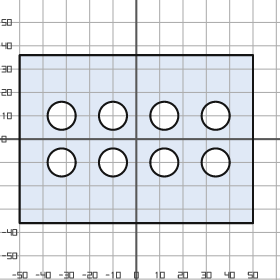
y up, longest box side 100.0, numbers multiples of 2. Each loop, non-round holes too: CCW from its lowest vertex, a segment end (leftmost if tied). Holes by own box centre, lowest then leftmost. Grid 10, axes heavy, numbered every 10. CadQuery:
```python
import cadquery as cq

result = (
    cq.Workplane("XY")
    .moveTo(-50.0, -36.0)
    .lineTo(50.0, -36.0)
    .lineTo(50.0, 36.0)
    .lineTo(-50.0, 36.0)
    .close()
    .moveTo(-32.0, -10.0)
    .circle(6.0)
    .moveTo(-10.0, -10.0)
    .circle(6.0)
    .moveTo(12.0, -10.0)
    .circle(6.0)
    .moveTo(34.0, -10.0)
    .circle(6.0)
    .moveTo(-32.0, 10.0)
    .circle(6.0)
    .moveTo(-10.0, 10.0)
    .circle(6.0)
    .moveTo(12.0, 10.0)
    .circle(6.0)
    .moveTo(34.0, 10.0)
    .circle(6.0)
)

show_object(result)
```